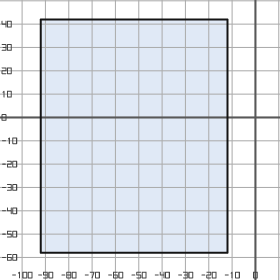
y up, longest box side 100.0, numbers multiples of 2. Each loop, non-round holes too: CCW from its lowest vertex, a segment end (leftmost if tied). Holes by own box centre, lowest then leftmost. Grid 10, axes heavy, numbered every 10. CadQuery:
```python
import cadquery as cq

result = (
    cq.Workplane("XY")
    .moveTo(-92.0, -58.0)
    .lineTo(-12.0, -58.0)
    .lineTo(-12.0, 42.0)
    .lineTo(-92.0, 42.0)
    .close()
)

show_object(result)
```